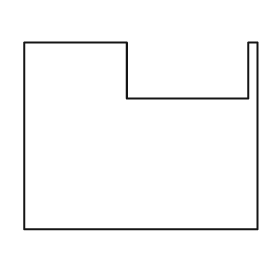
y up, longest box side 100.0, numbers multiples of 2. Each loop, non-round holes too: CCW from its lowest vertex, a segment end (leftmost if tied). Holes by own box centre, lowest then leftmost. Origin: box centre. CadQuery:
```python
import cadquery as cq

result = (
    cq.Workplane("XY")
    .moveTo(-50.0, -40.0)
    .lineTo(50.0, -40.0)
    .lineTo(50.0, 40.0)
    .lineTo(46.0, 40.0)
    .lineTo(46.0, 16.0)
    .lineTo(-6.0, 16.0)
    .lineTo(-6.0, 40.0)
    .lineTo(-50.0, 40.0)
    .close()
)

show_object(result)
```